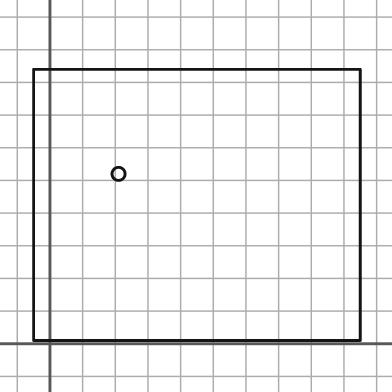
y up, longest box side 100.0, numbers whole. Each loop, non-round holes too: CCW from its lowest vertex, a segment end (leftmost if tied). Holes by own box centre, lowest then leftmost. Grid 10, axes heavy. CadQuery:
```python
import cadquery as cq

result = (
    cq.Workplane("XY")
    .moveTo(-5.0, 1.0)
    .lineTo(95.0, 1.0)
    .lineTo(95.0, 84.0)
    .lineTo(-5.0, 84.0)
    .close()
    .moveTo(21.0, 52.0)
    .circle(2.0)
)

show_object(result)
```